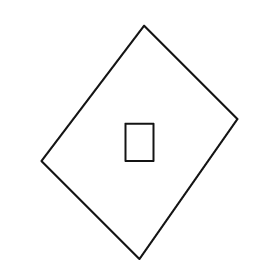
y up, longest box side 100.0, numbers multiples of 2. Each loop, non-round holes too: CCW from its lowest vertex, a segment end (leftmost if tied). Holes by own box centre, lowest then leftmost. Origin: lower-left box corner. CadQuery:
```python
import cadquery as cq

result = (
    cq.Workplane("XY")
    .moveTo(42.0, 0.0)
    .lineTo(84.0, 60.0)
    .lineTo(44.0, 100.0)
    .lineTo(0.0, 42.0)
    .close()
    .moveTo(36.0, 42.0)
    .lineTo(48.0, 42.0)
    .lineTo(48.0, 58.0)
    .lineTo(36.0, 58.0)
    .close()
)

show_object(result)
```